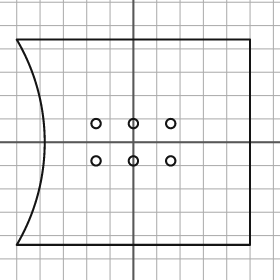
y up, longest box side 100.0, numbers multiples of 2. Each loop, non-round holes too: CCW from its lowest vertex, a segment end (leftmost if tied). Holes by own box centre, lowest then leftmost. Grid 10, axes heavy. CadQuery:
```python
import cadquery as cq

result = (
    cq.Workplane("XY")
    .moveTo(-50.0, -44.0)
    .lineTo(50.0, -44.0)
    .lineTo(50.0, 44.0)
    .lineTo(-50.0, 44.0)
    .threePointArc((-38.0, 0.0), (-50.0, -44.0))
    .close()
    .moveTo(-16.0, -8.0)
    .circle(2.0)
    .moveTo(0.0, -8.0)
    .circle(2.0)
    .moveTo(16.0, -8.0)
    .circle(2.0)
    .moveTo(-16.0, 8.0)
    .circle(2.0)
    .moveTo(0.0, 8.0)
    .circle(2.0)
    .moveTo(16.0, 8.0)
    .circle(2.0)
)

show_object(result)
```